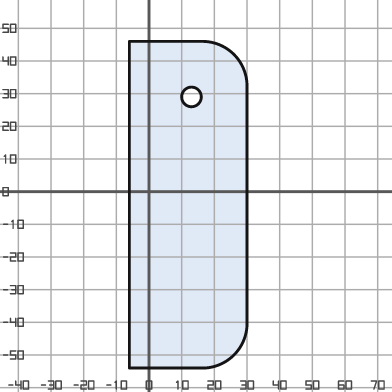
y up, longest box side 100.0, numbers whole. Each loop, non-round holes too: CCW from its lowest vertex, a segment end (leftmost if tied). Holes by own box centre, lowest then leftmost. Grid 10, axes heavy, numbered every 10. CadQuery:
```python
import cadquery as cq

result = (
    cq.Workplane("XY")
    .moveTo(-6.0, -54.0)
    .lineTo(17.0, -54.0)
    .threePointArc((26.0, -50.0), (30.0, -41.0))
    .lineTo(30.0, 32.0)
    .threePointArc((26.0, 42.0), (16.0, 46.0))
    .lineTo(-6.0, 46.0)
    .close()
    .moveTo(13.0, 29.0)
    .circle(3.0)
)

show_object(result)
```